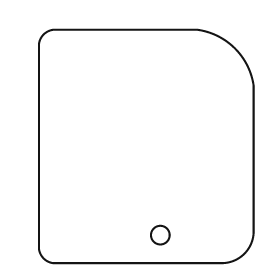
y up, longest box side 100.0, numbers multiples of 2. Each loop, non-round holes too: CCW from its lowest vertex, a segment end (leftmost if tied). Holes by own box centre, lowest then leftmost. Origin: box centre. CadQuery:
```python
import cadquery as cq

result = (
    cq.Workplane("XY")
    .moveTo(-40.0, -50.0)
    .lineTo(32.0, -50.0)
    .threePointArc((42.0, -46.0), (46.0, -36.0))
    .lineTo(46.0, 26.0)
    .threePointArc((38.0, 42.0), (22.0, 50.0))
    .lineTo(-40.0, 50.0)
    .threePointArc((-44.0, 48.0), (-46.0, 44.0))
    .lineTo(-46.0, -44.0)
    .threePointArc((-44.0, -48.0), (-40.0, -50.0))
    .close()
    .moveTo(6.0, -38.0)
    .circle(4.0)
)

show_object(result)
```